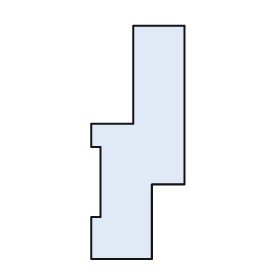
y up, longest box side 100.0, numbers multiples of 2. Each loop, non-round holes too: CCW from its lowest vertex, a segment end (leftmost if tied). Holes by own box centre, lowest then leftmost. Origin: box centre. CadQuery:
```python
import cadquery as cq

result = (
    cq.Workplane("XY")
    .moveTo(-20.0, -50.0)
    .lineTo(6.0, -50.0)
    .lineTo(6.0, -18.0)
    .lineTo(20.0, -18.0)
    .lineTo(20.0, 50.0)
    .lineTo(-2.0, 50.0)
    .lineTo(-2.0, 8.0)
    .lineTo(-20.0, 8.0)
    .lineTo(-20.0, -2.0)
    .lineTo(-16.0, -2.0)
    .lineTo(-16.0, -32.0)
    .lineTo(-20.0, -32.0)
    .close()
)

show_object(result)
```